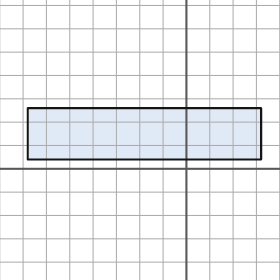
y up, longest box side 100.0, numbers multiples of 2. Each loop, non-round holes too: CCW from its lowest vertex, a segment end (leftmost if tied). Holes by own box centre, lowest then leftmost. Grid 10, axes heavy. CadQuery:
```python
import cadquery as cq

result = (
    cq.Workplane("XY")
    .moveTo(-68.0, 4.0)
    .lineTo(32.0, 4.0)
    .lineTo(32.0, 26.0)
    .lineTo(-68.0, 26.0)
    .close()
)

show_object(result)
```